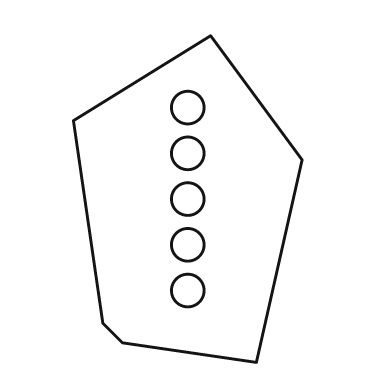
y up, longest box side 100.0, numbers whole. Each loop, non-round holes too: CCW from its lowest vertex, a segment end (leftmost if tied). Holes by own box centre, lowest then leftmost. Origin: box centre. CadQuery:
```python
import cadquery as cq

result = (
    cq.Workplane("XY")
    .moveTo(21.0, -50.0)
    .lineTo(35.0, 12.0)
    .lineTo(7.0, 50.0)
    .lineTo(-35.0, 24.0)
    .lineTo(-26.0, -38.0)
    .lineTo(-20.0, -44.0)
    .close()
    .moveTo(0.0, -28.0)
    .circle(5.0)
    .moveTo(0.0, -14.0)
    .circle(5.0)
    .moveTo(0.0, 0.0)
    .circle(5.0)
    .moveTo(0.0, 14.0)
    .circle(5.0)
    .moveTo(0.0, 28.0)
    .circle(5.0)
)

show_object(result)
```